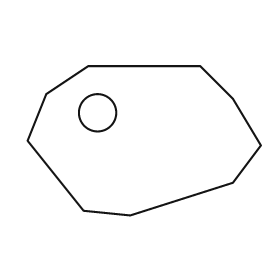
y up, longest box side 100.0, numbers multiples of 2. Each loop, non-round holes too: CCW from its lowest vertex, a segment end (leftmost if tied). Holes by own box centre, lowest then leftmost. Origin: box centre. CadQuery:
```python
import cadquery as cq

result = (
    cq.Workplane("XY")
    .moveTo(-6.0, -32.0)
    .lineTo(38.0, -18.0)
    .lineTo(50.0, -2.0)
    .lineTo(38.0, 18.0)
    .lineTo(24.0, 32.0)
    .lineTo(-24.0, 32.0)
    .lineTo(-42.0, 20.0)
    .lineTo(-50.0, 0.0)
    .lineTo(-26.0, -30.0)
    .close()
    .moveTo(-20.0, 12.0)
    .circle(8.0)
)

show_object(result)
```